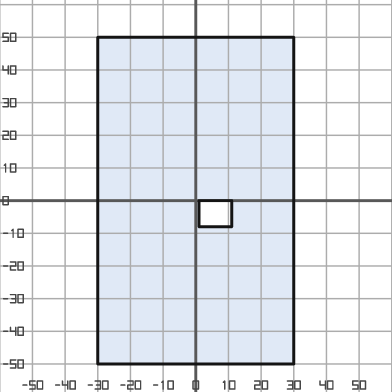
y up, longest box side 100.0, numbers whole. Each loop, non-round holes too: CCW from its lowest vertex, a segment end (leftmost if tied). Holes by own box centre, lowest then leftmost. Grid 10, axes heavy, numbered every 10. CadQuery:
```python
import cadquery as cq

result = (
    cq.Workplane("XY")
    .moveTo(-30.0, -50.0)
    .lineTo(30.0, -50.0)
    .lineTo(30.0, 50.0)
    .lineTo(-30.0, 50.0)
    .close()
    .moveTo(1.0, -8.0)
    .lineTo(11.0, -8.0)
    .lineTo(11.0, 0.0)
    .lineTo(1.0, 0.0)
    .close()
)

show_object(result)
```